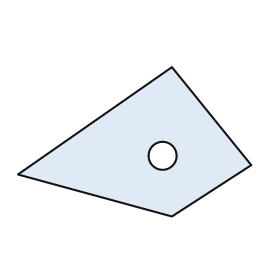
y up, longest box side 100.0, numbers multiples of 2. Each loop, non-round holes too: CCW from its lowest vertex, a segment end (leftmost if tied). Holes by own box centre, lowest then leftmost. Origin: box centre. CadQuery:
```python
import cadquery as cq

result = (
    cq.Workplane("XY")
    .moveTo(16.0, -32.0)
    .lineTo(50.0, -10.0)
    .lineTo(16.0, 32.0)
    .lineTo(-50.0, -14.0)
    .close()
    .moveTo(12.0, -6.0)
    .circle(6.0)
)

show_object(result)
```